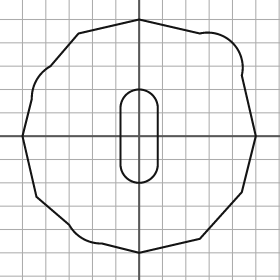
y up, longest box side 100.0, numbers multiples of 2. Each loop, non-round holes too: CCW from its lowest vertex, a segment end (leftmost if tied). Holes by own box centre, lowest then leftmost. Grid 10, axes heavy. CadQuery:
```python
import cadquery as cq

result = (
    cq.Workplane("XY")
    .moveTo(0.0, -50.0)
    .lineTo(26.0, -44.0)
    .lineTo(44.0, -24.0)
    .lineTo(50.0, 0.0)
    .lineTo(44.0, 26.0)
    .threePointArc((40.0, 40.0), (26.0, 44.0))
    .lineTo(0.0, 50.0)
    .lineTo(-26.0, 44.0)
    .lineTo(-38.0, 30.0)
    .threePointArc((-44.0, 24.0), (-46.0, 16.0))
    .lineTo(-50.0, 0.0)
    .lineTo(-44.0, -26.0)
    .lineTo(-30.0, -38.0)
    .threePointArc((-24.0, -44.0), (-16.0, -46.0))
    .close()
    .moveTo(-8.0, -12.0)
    .threePointArc((0.0, -20.0), (8.0, -12.0))
    .lineTo(8.0, 12.0)
    .threePointArc((0.0, 20.0), (-8.0, 12.0))
    .close()
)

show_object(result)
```